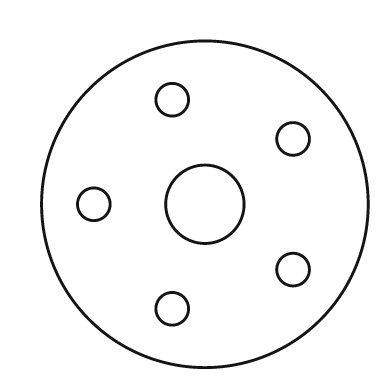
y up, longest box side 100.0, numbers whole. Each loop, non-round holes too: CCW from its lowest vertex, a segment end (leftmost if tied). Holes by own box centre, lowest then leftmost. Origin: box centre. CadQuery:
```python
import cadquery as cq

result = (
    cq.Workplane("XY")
    .moveTo(0.0, 0.0)
    .circle(50.0)
    .moveTo(-10.0, -32.0)
    .circle(5.0)
    .moveTo(27.0, -20.0)
    .circle(5.0)
    .moveTo(-34.0, 0.0)
    .circle(5.0)
    .moveTo(0.0, 0.0)
    .circle(12.0)
    .moveTo(27.0, 20.0)
    .circle(5.0)
    .moveTo(-10.0, 32.0)
    .circle(5.0)
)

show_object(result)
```